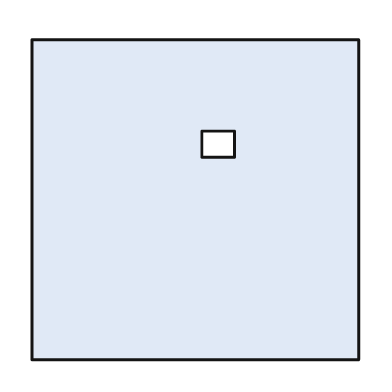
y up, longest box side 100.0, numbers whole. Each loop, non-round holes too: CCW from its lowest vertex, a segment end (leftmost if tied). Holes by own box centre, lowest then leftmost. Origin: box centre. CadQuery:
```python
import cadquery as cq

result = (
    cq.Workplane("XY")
    .moveTo(-50.0, -49.0)
    .lineTo(50.0, -49.0)
    .lineTo(50.0, 49.0)
    .lineTo(-50.0, 49.0)
    .close()
    .moveTo(2.0, 13.0)
    .lineTo(12.0, 13.0)
    .lineTo(12.0, 21.0)
    .lineTo(2.0, 21.0)
    .close()
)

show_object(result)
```